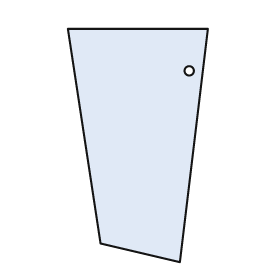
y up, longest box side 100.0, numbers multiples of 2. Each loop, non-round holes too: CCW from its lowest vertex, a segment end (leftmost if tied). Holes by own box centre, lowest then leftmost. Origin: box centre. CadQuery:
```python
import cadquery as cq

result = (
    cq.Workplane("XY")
    .moveTo(18.0, -50.0)
    .lineTo(30.0, 50.0)
    .lineTo(-30.0, 50.0)
    .lineTo(-16.0, -42.0)
    .close()
    .moveTo(22.0, 32.0)
    .circle(2.0)
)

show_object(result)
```